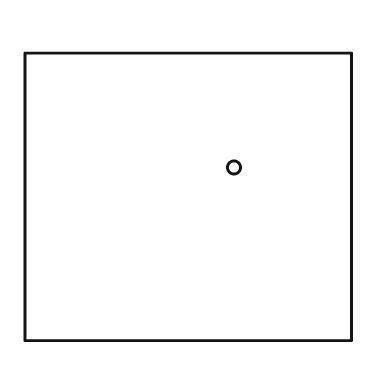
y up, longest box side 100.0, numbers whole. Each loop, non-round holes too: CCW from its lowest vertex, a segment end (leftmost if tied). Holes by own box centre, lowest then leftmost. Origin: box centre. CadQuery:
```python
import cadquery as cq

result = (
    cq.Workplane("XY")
    .moveTo(-50.0, -44.0)
    .lineTo(50.0, -44.0)
    .lineTo(50.0, 44.0)
    .lineTo(-50.0, 44.0)
    .close()
    .moveTo(14.0, 9.0)
    .circle(2.0)
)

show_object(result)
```